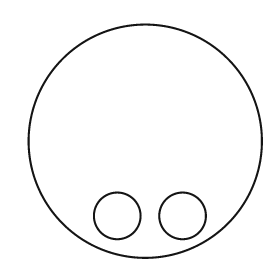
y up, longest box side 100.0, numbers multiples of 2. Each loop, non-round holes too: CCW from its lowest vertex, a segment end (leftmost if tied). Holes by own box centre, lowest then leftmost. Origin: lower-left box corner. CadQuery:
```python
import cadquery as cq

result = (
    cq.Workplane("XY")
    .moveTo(50.0, 50.0)
    .circle(50.0)
    .moveTo(38.0, 18.0)
    .circle(10.0)
    .moveTo(66.0, 18.0)
    .circle(10.0)
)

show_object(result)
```